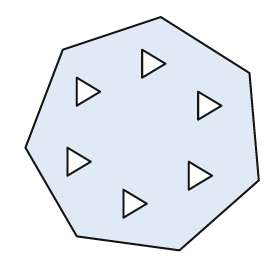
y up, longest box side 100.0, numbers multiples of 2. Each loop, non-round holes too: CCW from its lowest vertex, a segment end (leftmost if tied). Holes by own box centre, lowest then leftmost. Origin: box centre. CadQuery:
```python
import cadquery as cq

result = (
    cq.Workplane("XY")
    .moveTo(16.0, -50.0)
    .lineTo(50.0, -20.0)
    .lineTo(46.0, 26.0)
    .lineTo(8.0, 50.0)
    .lineTo(-34.0, 36.0)
    .lineTo(-50.0, -6.0)
    .lineTo(-28.0, -44.0)
    .close()
    .moveTo(-8.0, -36.0)
    .lineTo(2.0, -30.0)
    .lineTo(-8.0, -24.0)
    .close()
    .moveTo(20.0, -24.0)
    .lineTo(30.0, -18.0)
    .lineTo(20.0, -12.0)
    .close()
    .moveTo(-32.0, -18.0)
    .lineTo(-22.0, -12.0)
    .lineTo(-32.0, -6.0)
    .close()
    .moveTo(24.0, 6.0)
    .lineTo(34.0, 12.0)
    .lineTo(24.0, 18.0)
    .close()
    .moveTo(-28.0, 12.0)
    .lineTo(-18.0, 18.0)
    .lineTo(-28.0, 24.0)
    .close()
    .moveTo(0.0, 24.0)
    .lineTo(10.0, 30.0)
    .lineTo(0.0, 36.0)
    .close()
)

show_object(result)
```